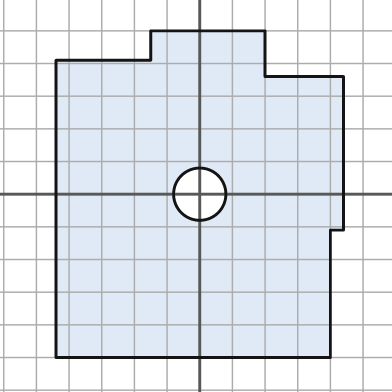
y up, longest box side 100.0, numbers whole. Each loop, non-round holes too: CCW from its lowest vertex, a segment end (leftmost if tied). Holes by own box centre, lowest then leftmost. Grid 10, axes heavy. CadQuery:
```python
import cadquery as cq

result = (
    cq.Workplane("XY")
    .moveTo(-44.0, -50.0)
    .lineTo(40.0, -50.0)
    .lineTo(40.0, -11.0)
    .lineTo(44.0, -11.0)
    .lineTo(44.0, 36.0)
    .lineTo(20.0, 36.0)
    .lineTo(20.0, 50.0)
    .lineTo(-15.0, 50.0)
    .lineTo(-15.0, 41.0)
    .lineTo(-44.0, 41.0)
    .close()
    .moveTo(0.0, 0.0)
    .circle(8.0)
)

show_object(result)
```